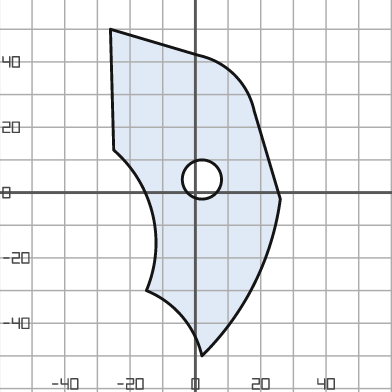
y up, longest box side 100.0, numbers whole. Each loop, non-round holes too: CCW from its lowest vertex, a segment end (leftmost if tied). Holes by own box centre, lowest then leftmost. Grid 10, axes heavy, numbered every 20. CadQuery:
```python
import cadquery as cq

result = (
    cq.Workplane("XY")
    .moveTo(2.0, -50.0)
    .threePointArc((18.0, -28.0), (26.0, -2.0))
    .lineTo(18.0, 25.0)
    .threePointArc((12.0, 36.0), (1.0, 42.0))
    .lineTo(-26.0, 50.0)
    .lineTo(-25.0, 13.0)
    .threePointArc((-13.0, -7.0), (-15.0, -30.0))
    .threePointArc((-4.0, -38.0), (2.0, -50.0))
    .close()
    .moveTo(2.0, 4.0)
    .circle(6.0)
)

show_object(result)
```